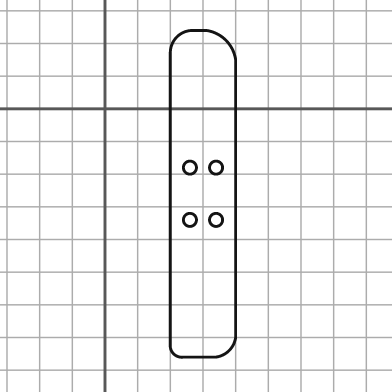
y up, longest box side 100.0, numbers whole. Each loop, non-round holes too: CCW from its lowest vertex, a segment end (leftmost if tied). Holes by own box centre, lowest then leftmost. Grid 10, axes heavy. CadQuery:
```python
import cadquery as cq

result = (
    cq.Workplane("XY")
    .moveTo(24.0, -76.0)
    .lineTo(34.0, -76.0)
    .threePointArc((38.0, -74.0), (40.0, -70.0))
    .lineTo(40.0, 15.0)
    .threePointArc((37.0, 21.0), (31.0, 24.0))
    .lineTo(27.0, 24.0)
    .threePointArc((22.0, 22.0), (20.0, 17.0))
    .lineTo(20.0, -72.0)
    .threePointArc((21.0, -75.0), (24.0, -76.0))
    .close()
    .moveTo(26.0, -34.0)
    .circle(2.0)
    .moveTo(34.0, -34.0)
    .circle(2.0)
    .moveTo(26.0, -18.0)
    .circle(2.0)
    .moveTo(34.0, -18.0)
    .circle(2.0)
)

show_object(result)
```